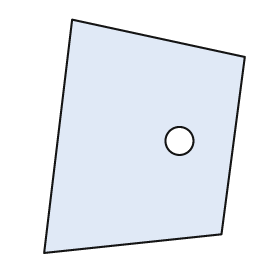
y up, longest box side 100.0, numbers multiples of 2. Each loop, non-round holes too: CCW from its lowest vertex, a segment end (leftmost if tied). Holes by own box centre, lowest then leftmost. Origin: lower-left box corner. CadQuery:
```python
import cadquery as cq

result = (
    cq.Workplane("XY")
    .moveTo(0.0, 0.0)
    .lineTo(76.0, 8.0)
    .lineTo(86.0, 84.0)
    .lineTo(12.0, 100.0)
    .close()
    .moveTo(58.0, 48.0)
    .circle(6.0)
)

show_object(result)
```